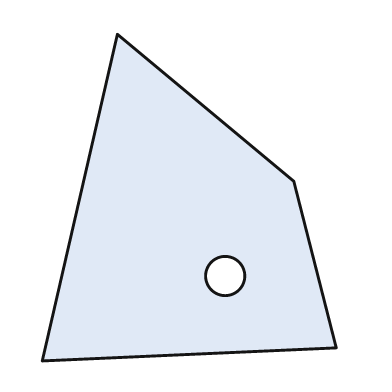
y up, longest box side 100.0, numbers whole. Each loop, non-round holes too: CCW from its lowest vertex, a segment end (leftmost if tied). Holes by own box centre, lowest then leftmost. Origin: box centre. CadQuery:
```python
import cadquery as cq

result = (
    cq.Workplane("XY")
    .moveTo(-45.0, -50.0)
    .lineTo(45.0, -46.0)
    .lineTo(32.0, 5.0)
    .lineTo(-22.0, 50.0)
    .close()
    .moveTo(11.0, -24.0)
    .circle(6.0)
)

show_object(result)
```